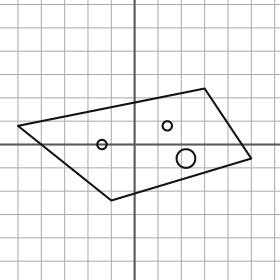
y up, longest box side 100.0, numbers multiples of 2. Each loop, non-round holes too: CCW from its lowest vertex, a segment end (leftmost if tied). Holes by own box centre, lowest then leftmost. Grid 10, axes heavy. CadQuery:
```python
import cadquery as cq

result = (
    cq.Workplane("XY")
    .moveTo(-10.0, -24.0)
    .lineTo(50.0, -6.0)
    .lineTo(30.0, 24.0)
    .lineTo(-50.0, 8.0)
    .close()
    .moveTo(22.0, -6.0)
    .circle(4.0)
    .moveTo(-14.0, 0.0)
    .circle(2.0)
    .moveTo(14.0, 8.0)
    .circle(2.0)
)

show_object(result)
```